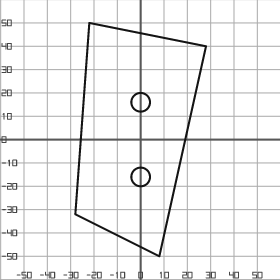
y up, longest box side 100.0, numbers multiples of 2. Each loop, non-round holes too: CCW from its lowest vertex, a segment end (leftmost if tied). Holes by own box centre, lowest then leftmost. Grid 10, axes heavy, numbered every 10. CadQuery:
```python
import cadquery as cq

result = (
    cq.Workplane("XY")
    .moveTo(8.0, -50.0)
    .lineTo(28.0, 40.0)
    .lineTo(-22.0, 50.0)
    .lineTo(-28.0, -32.0)
    .close()
    .moveTo(0.0, -16.0)
    .circle(4.0)
    .moveTo(0.0, 16.0)
    .circle(4.0)
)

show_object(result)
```